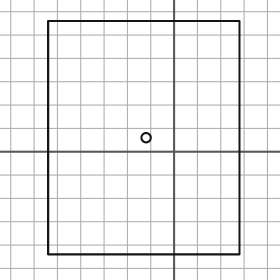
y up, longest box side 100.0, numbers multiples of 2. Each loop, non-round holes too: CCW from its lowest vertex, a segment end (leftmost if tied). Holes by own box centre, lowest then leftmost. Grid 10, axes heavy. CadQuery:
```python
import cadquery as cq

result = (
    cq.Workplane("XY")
    .moveTo(-54.0, -44.0)
    .lineTo(28.0, -44.0)
    .lineTo(28.0, 56.0)
    .lineTo(-54.0, 56.0)
    .close()
    .moveTo(-12.0, 6.0)
    .circle(2.0)
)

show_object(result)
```